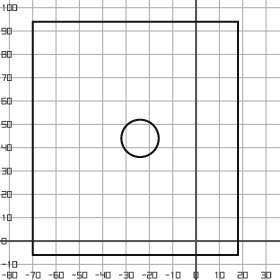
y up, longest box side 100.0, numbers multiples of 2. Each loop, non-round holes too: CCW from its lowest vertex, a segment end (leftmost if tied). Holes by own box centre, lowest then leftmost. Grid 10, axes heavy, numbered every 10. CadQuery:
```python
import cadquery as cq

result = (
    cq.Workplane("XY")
    .moveTo(-70.0, -6.0)
    .lineTo(18.0, -6.0)
    .lineTo(18.0, 94.0)
    .lineTo(-70.0, 94.0)
    .close()
    .moveTo(-24.0, 44.0)
    .circle(8.0)
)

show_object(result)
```